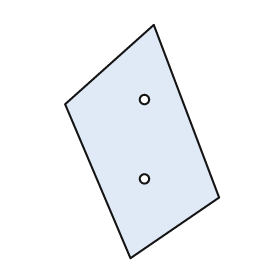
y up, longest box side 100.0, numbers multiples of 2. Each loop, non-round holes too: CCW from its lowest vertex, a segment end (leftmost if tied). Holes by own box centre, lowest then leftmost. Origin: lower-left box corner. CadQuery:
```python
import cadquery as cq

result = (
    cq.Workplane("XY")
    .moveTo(28.0, 0.0)
    .lineTo(66.0, 26.0)
    .lineTo(38.0, 100.0)
    .lineTo(0.0, 66.0)
    .close()
    .moveTo(34.0, 34.0)
    .circle(2.0)
    .moveTo(34.0, 68.0)
    .circle(2.0)
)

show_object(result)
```